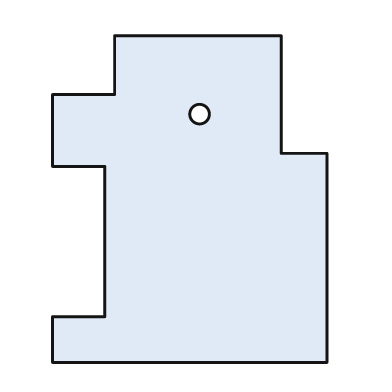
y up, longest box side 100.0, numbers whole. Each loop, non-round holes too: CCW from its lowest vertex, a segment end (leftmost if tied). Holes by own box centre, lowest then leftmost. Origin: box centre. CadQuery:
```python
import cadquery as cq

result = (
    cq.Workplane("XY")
    .moveTo(-42.0, -50.0)
    .lineTo(42.0, -50.0)
    .lineTo(42.0, 14.0)
    .lineTo(28.0, 14.0)
    .lineTo(28.0, 50.0)
    .lineTo(-23.0, 50.0)
    .lineTo(-23.0, 32.0)
    .lineTo(-42.0, 32.0)
    .lineTo(-42.0, 10.0)
    .lineTo(-26.0, 10.0)
    .lineTo(-26.0, -36.0)
    .lineTo(-42.0, -36.0)
    .close()
    .moveTo(3.0, 26.0)
    .circle(3.0)
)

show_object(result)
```